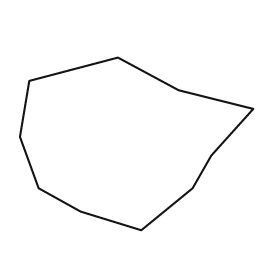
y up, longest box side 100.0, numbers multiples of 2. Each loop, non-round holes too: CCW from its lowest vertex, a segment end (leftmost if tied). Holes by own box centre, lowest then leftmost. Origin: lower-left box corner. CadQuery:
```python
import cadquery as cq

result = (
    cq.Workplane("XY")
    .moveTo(52.0, 0.0)
    .lineTo(74.0, 18.0)
    .lineTo(82.0, 32.0)
    .lineTo(100.0, 52.0)
    .lineTo(68.0, 60.0)
    .lineTo(42.0, 74.0)
    .lineTo(4.0, 64.0)
    .lineTo(0.0, 40.0)
    .lineTo(8.0, 18.0)
    .lineTo(26.0, 8.0)
    .close()
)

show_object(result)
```